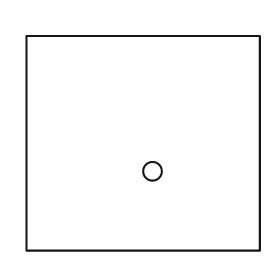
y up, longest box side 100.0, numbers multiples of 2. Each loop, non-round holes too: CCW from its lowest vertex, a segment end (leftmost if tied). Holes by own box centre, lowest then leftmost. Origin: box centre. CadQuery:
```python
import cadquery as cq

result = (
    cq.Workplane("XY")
    .moveTo(-50.0, -46.0)
    .lineTo(50.0, -46.0)
    .lineTo(50.0, 46.0)
    .lineTo(-50.0, 46.0)
    .close()
    .moveTo(4.0, -12.0)
    .circle(4.0)
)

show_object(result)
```